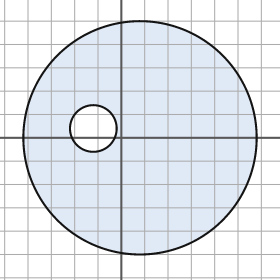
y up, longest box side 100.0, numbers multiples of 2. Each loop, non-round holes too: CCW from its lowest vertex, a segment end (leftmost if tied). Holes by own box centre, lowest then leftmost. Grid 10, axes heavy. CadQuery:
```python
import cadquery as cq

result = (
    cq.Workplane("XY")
    .moveTo(8.0, 0.0)
    .circle(50.0)
    .moveTo(-12.0, 4.0)
    .circle(10.0)
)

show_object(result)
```